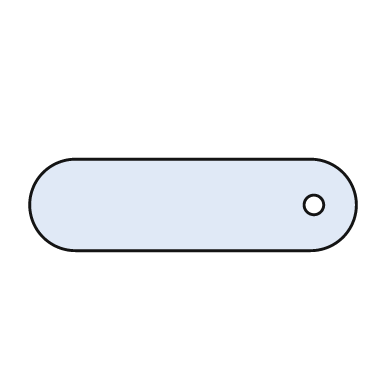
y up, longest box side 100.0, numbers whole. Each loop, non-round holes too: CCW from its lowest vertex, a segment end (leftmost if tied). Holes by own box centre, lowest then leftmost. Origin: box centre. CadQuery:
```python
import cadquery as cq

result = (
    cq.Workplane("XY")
    .moveTo(-36.0, -14.0)
    .lineTo(36.0, -14.0)
    .threePointArc((50.0, 0.0), (36.0, 14.0))
    .lineTo(-36.0, 14.0)
    .threePointArc((-50.0, 0.0), (-36.0, -14.0))
    .close()
    .moveTo(37.0, 0.0)
    .circle(3.0)
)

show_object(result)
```